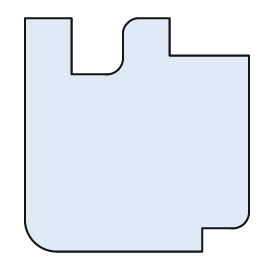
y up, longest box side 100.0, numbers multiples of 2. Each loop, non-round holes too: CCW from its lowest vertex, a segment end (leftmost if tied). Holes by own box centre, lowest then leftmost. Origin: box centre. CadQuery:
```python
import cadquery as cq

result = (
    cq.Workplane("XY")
    .moveTo(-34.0, -50.0)
    .lineTo(28.0, -50.0)
    .lineTo(28.0, -40.0)
    .lineTo(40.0, -40.0)
    .threePointArc((46.0, -38.0), (48.0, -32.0))
    .lineTo(48.0, 34.0)
    .lineTo(14.0, 34.0)
    .lineTo(14.0, 50.0)
    .lineTo(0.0, 50.0)
    .threePointArc((-4.0, 48.0), (-6.0, 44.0))
    .lineTo(-6.0, 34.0)
    .threePointArc((-8.0, 28.0), (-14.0, 26.0))
    .lineTo(-28.0, 26.0)
    .lineTo(-28.0, 50.0)
    .lineTo(-48.0, 50.0)
    .lineTo(-48.0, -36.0)
    .threePointArc((-44.0, -46.0), (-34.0, -50.0))
    .close()
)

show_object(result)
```